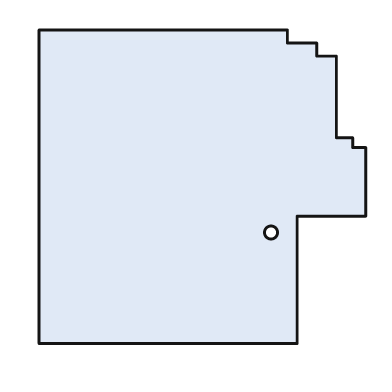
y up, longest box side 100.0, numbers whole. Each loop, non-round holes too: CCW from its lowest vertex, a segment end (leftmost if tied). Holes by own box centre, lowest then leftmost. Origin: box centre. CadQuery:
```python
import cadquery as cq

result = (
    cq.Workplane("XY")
    .moveTo(-50.0, -48.0)
    .lineTo(29.0, -48.0)
    .lineTo(29.0, -9.0)
    .lineTo(50.0, -9.0)
    .lineTo(50.0, 12.0)
    .lineTo(46.0, 12.0)
    .lineTo(46.0, 15.0)
    .lineTo(41.0, 15.0)
    .lineTo(41.0, 40.0)
    .lineTo(35.0, 40.0)
    .lineTo(35.0, 44.0)
    .lineTo(26.0, 44.0)
    .lineTo(26.0, 48.0)
    .lineTo(-50.0, 48.0)
    .close()
    .moveTo(21.0, -14.0)
    .circle(2.0)
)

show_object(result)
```